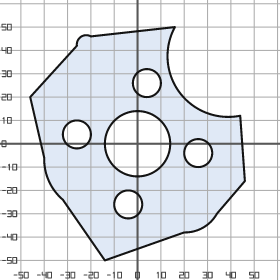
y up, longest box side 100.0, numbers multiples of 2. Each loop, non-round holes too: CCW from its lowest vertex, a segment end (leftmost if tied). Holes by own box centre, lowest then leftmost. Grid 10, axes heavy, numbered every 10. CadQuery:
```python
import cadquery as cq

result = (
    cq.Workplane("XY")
    .moveTo(-14.0, -50.0)
    .lineTo(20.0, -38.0)
    .threePointArc((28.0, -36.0), (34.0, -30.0))
    .lineTo(46.0, -16.0)
    .lineTo(44.0, 12.0)
    .threePointArc((18.0, 22.0), (16.0, 50.0))
    .lineTo(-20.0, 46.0)
    .threePointArc((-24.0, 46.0), (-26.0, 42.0))
    .lineTo(-46.0, 20.0)
    .lineTo(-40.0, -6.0)
    .threePointArc((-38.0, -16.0), (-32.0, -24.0))
    .close()
    .moveTo(-4.0, -26.0)
    .circle(6.0)
    .moveTo(26.0, -4.0)
    .circle(6.0)
    .moveTo(0.0, 0.0)
    .circle(14.0)
    .moveTo(-26.0, 4.0)
    .circle(6.0)
    .moveTo(4.0, 26.0)
    .circle(6.0)
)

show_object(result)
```